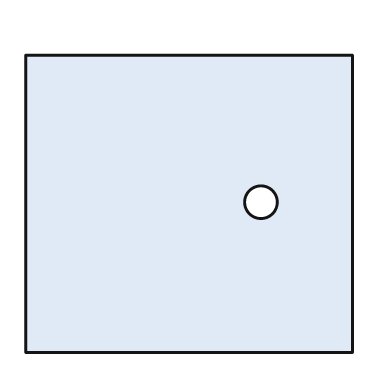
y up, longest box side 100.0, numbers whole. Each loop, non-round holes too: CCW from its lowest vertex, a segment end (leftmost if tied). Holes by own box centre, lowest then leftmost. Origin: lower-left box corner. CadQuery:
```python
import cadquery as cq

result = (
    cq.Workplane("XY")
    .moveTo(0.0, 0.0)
    .lineTo(100.0, 0.0)
    .lineTo(100.0, 91.0)
    .lineTo(0.0, 91.0)
    .close()
    .moveTo(72.0, 46.0)
    .circle(5.0)
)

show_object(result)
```